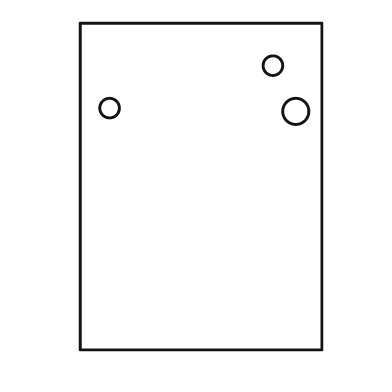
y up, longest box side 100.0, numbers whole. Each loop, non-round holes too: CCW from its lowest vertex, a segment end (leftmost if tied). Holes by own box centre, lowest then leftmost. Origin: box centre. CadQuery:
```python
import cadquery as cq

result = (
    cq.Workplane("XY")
    .moveTo(-37.0, -50.0)
    .lineTo(37.0, -50.0)
    .lineTo(37.0, 50.0)
    .lineTo(-37.0, 50.0)
    .close()
    .moveTo(29.0, 23.0)
    .circle(4.0)
    .moveTo(-28.0, 24.0)
    .circle(3.0)
    .moveTo(22.0, 37.0)
    .circle(3.0)
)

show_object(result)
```